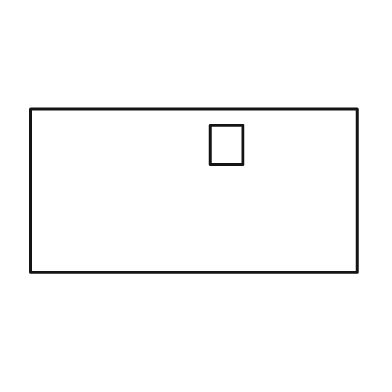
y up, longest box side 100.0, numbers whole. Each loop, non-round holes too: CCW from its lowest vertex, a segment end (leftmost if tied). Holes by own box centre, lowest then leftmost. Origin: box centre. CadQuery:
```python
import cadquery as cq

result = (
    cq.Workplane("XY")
    .moveTo(-50.0, -25.0)
    .lineTo(50.0, -25.0)
    .lineTo(50.0, 25.0)
    .lineTo(-50.0, 25.0)
    .close()
    .moveTo(5.0, 8.0)
    .lineTo(15.0, 8.0)
    .lineTo(15.0, 20.0)
    .lineTo(5.0, 20.0)
    .close()
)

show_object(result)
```